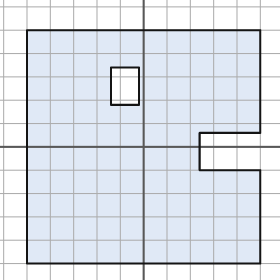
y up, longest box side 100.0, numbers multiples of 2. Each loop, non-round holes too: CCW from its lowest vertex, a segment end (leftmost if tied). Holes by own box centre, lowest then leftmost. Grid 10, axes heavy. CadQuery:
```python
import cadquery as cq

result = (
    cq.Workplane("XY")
    .moveTo(-50.0, -50.0)
    .lineTo(50.0, -50.0)
    .lineTo(50.0, -10.0)
    .lineTo(24.0, -10.0)
    .lineTo(24.0, 6.0)
    .lineTo(50.0, 6.0)
    .lineTo(50.0, 50.0)
    .lineTo(-50.0, 50.0)
    .close()
    .moveTo(-14.0, 18.0)
    .lineTo(-2.0, 18.0)
    .lineTo(-2.0, 34.0)
    .lineTo(-14.0, 34.0)
    .close()
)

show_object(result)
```